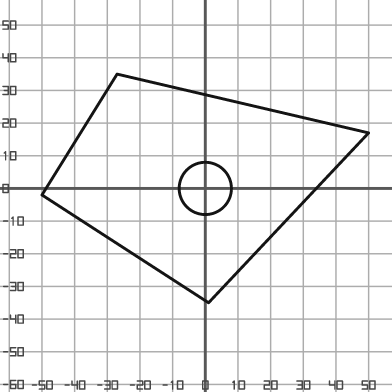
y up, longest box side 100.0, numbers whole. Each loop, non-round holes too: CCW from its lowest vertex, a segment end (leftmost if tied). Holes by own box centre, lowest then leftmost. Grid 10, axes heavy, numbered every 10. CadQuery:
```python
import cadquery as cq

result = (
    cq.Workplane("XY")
    .moveTo(1.0, -35.0)
    .lineTo(50.0, 17.0)
    .lineTo(-27.0, 35.0)
    .lineTo(-50.0, -2.0)
    .close()
    .moveTo(0.0, 0.0)
    .circle(8.0)
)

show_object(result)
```